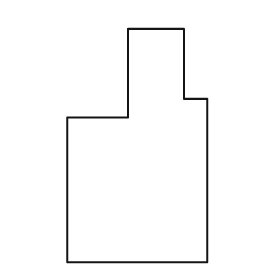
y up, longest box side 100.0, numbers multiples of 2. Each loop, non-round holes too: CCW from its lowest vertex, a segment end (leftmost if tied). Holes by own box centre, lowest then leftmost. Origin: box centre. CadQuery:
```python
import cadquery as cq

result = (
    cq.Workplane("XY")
    .moveTo(-30.0, -50.0)
    .lineTo(30.0, -50.0)
    .lineTo(30.0, 20.0)
    .lineTo(20.0, 20.0)
    .lineTo(20.0, 50.0)
    .lineTo(-4.0, 50.0)
    .lineTo(-4.0, 12.0)
    .lineTo(-30.0, 12.0)
    .close()
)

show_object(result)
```